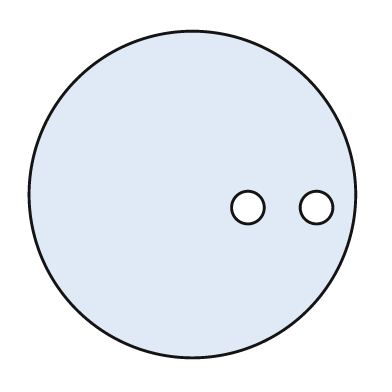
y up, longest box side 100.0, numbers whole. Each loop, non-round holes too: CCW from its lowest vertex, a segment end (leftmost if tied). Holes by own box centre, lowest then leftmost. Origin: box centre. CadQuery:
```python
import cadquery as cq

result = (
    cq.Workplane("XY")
    .moveTo(0.0, 0.0)
    .circle(50.0)
    .moveTo(17.0, -4.0)
    .circle(5.0)
    .moveTo(38.0, -4.0)
    .circle(5.0)
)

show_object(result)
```